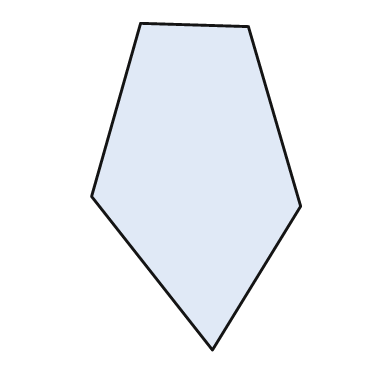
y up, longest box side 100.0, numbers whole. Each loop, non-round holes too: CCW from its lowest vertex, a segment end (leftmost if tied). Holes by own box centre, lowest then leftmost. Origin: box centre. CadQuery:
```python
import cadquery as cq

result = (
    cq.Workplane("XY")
    .moveTo(5.0, -50.0)
    .lineTo(32.0, -6.0)
    .lineTo(16.0, 49.0)
    .lineTo(-17.0, 50.0)
    .lineTo(-32.0, -3.0)
    .close()
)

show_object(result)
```